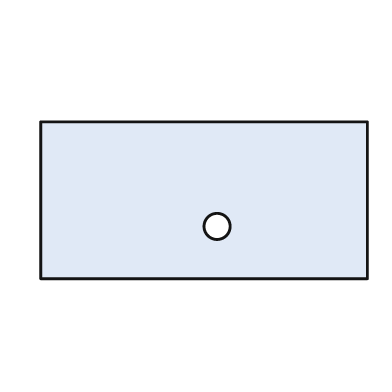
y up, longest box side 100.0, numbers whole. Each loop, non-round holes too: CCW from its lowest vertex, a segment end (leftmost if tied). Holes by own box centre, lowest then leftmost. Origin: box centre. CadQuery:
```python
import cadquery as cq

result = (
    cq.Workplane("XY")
    .moveTo(-50.0, -24.0)
    .lineTo(50.0, -24.0)
    .lineTo(50.0, 24.0)
    .lineTo(-50.0, 24.0)
    .close()
    .moveTo(4.0, -8.0)
    .circle(4.0)
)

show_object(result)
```